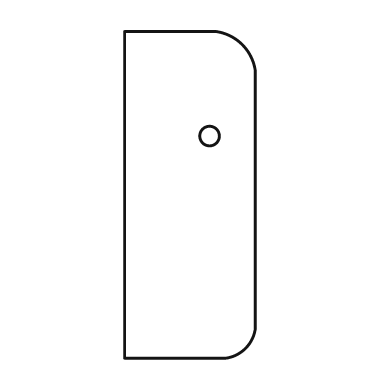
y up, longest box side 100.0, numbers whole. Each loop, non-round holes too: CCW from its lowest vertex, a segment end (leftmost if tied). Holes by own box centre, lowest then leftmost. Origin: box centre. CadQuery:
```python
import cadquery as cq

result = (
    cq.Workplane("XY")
    .moveTo(-20.0, -50.0)
    .lineTo(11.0, -50.0)
    .threePointArc((17.0, -47.0), (20.0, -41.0))
    .lineTo(20.0, 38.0)
    .threePointArc((16.0, 46.0), (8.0, 50.0))
    .lineTo(-20.0, 50.0)
    .close()
    .moveTo(6.0, 18.0)
    .circle(3.0)
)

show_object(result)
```